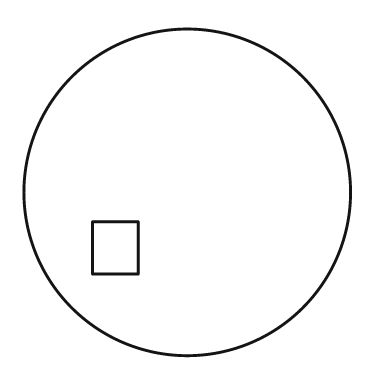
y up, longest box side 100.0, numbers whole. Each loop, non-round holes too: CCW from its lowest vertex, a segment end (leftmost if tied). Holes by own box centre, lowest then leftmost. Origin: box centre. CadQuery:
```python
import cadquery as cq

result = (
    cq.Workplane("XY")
    .moveTo(0.0, 0.0)
    .circle(50.0)
    .moveTo(-29.0, -25.0)
    .lineTo(-15.0, -25.0)
    .lineTo(-15.0, -9.0)
    .lineTo(-29.0, -9.0)
    .close()
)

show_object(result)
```